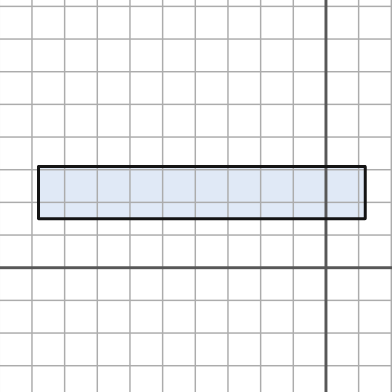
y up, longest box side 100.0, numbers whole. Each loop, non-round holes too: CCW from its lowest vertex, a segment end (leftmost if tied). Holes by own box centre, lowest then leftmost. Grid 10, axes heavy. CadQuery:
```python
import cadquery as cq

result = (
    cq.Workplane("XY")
    .moveTo(-88.0, 15.0)
    .lineTo(12.0, 15.0)
    .lineTo(12.0, 31.0)
    .lineTo(-88.0, 31.0)
    .close()
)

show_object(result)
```